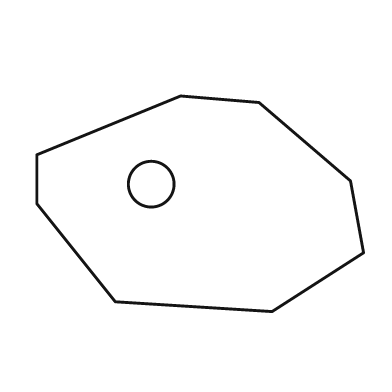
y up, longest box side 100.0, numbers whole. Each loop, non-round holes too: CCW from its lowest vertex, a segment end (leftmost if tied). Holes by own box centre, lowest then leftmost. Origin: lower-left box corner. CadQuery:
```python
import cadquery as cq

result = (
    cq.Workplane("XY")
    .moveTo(72.0, 0.0)
    .lineTo(100.0, 18.0)
    .lineTo(96.0, 40.0)
    .lineTo(68.0, 64.0)
    .lineTo(44.0, 66.0)
    .lineTo(0.0, 48.0)
    .lineTo(0.0, 33.0)
    .lineTo(24.0, 3.0)
    .close()
    .moveTo(35.0, 39.0)
    .circle(7.0)
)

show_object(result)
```